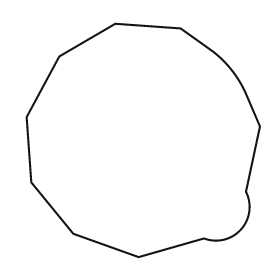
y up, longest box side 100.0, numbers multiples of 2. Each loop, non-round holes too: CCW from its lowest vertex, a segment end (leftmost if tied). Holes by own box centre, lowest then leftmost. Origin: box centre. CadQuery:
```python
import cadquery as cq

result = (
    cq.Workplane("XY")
    .moveTo(-2.0, -50.0)
    .lineTo(26.0, -42.0)
    .threePointArc((42.0, -38.0), (44.0, -22.0))
    .lineTo(50.0, 6.0)
    .lineTo(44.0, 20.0)
    .threePointArc((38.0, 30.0), (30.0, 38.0))
    .lineTo(16.0, 48.0)
    .lineTo(-12.0, 50.0)
    .lineTo(-36.0, 36.0)
    .lineTo(-50.0, 10.0)
    .lineTo(-48.0, -18.0)
    .lineTo(-30.0, -40.0)
    .close()
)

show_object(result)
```